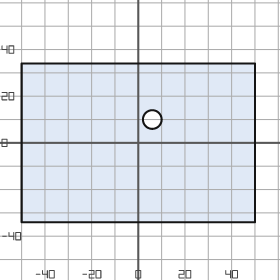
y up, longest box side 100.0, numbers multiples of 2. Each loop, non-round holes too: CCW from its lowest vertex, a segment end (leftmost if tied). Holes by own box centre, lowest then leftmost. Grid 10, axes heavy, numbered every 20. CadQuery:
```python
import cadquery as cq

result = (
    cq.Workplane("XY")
    .moveTo(-50.0, -34.0)
    .lineTo(50.0, -34.0)
    .lineTo(50.0, 34.0)
    .lineTo(-50.0, 34.0)
    .close()
    .moveTo(6.0, 10.0)
    .circle(4.0)
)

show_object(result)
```